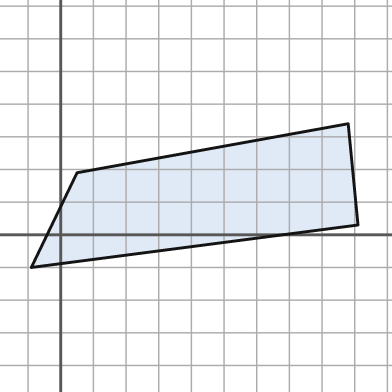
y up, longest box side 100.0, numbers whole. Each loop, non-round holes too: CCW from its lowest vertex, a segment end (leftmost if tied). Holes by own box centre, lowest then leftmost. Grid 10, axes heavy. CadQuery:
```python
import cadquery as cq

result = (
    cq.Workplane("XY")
    .moveTo(-9.0, -10.0)
    .lineTo(91.0, 3.0)
    .lineTo(88.0, 34.0)
    .lineTo(5.0, 19.0)
    .close()
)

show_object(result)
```